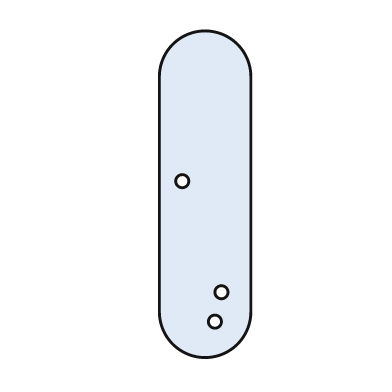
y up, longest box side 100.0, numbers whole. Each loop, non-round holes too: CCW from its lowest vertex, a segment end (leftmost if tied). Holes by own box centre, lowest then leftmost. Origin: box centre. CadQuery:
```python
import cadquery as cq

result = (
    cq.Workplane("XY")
    .moveTo(-14.0, -36.0)
    .threePointArc((0.0, -50.0), (14.0, -36.0))
    .lineTo(14.0, 36.0)
    .threePointArc((0.0, 50.0), (-14.0, 36.0))
    .close()
    .moveTo(3.0, -39.0)
    .circle(2.0)
    .moveTo(5.0, -30.0)
    .circle(2.0)
    .moveTo(-7.0, 4.0)
    .circle(2.0)
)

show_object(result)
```